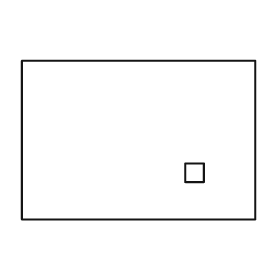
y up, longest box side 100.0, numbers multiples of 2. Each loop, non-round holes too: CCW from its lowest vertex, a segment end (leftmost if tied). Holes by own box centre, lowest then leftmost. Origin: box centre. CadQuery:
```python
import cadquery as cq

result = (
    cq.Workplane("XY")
    .moveTo(-50.0, -34.0)
    .lineTo(50.0, -34.0)
    .lineTo(50.0, 34.0)
    .lineTo(-50.0, 34.0)
    .close()
    .moveTo(20.0, -18.0)
    .lineTo(28.0, -18.0)
    .lineTo(28.0, -10.0)
    .lineTo(20.0, -10.0)
    .close()
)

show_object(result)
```